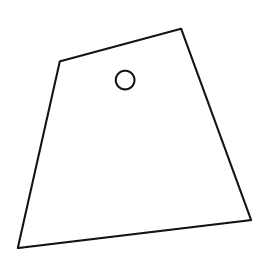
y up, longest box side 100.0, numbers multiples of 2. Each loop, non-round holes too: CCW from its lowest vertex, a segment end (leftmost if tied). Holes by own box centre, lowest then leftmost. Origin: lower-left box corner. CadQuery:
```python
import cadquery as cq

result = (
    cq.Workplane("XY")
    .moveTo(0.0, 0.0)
    .lineTo(100.0, 12.0)
    .lineTo(70.0, 94.0)
    .lineTo(18.0, 80.0)
    .close()
    .moveTo(46.0, 72.0)
    .circle(4.0)
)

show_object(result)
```